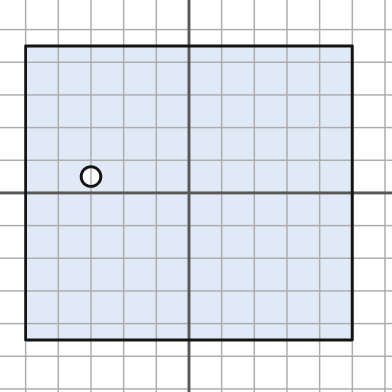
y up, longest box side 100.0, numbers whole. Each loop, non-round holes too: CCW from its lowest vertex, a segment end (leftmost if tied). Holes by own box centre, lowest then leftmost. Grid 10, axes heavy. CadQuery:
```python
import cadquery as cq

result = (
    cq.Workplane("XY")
    .moveTo(-50.0, -45.0)
    .lineTo(50.0, -45.0)
    .lineTo(50.0, 45.0)
    .lineTo(-50.0, 45.0)
    .close()
    .moveTo(-30.0, 5.0)
    .circle(3.0)
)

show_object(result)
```